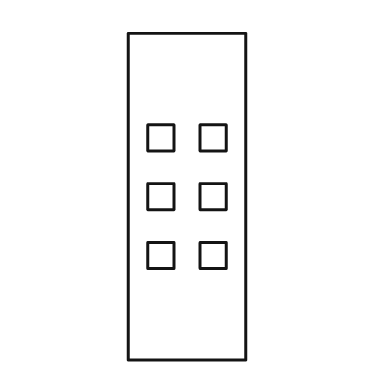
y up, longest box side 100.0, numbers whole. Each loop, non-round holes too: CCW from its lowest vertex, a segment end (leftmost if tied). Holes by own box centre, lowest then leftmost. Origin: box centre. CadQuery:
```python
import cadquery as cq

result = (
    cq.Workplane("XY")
    .moveTo(-18.0, -50.0)
    .lineTo(18.0, -50.0)
    .lineTo(18.0, 50.0)
    .lineTo(-18.0, 50.0)
    .close()
    .moveTo(-12.0, -22.0)
    .lineTo(-4.0, -22.0)
    .lineTo(-4.0, -14.0)
    .lineTo(-12.0, -14.0)
    .close()
    .moveTo(4.0, -22.0)
    .lineTo(12.0, -22.0)
    .lineTo(12.0, -14.0)
    .lineTo(4.0, -14.0)
    .close()
    .moveTo(-12.0, -4.0)
    .lineTo(-4.0, -4.0)
    .lineTo(-4.0, 4.0)
    .lineTo(-12.0, 4.0)
    .close()
    .moveTo(4.0, -4.0)
    .lineTo(12.0, -4.0)
    .lineTo(12.0, 4.0)
    .lineTo(4.0, 4.0)
    .close()
    .moveTo(-12.0, 14.0)
    .lineTo(-4.0, 14.0)
    .lineTo(-4.0, 22.0)
    .lineTo(-12.0, 22.0)
    .close()
    .moveTo(4.0, 14.0)
    .lineTo(12.0, 14.0)
    .lineTo(12.0, 22.0)
    .lineTo(4.0, 22.0)
    .close()
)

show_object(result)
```